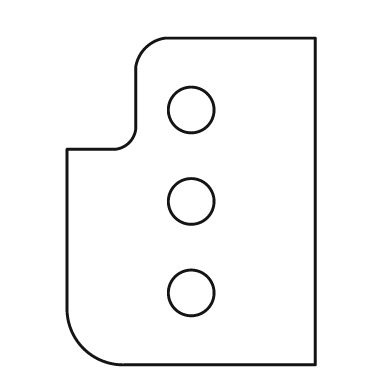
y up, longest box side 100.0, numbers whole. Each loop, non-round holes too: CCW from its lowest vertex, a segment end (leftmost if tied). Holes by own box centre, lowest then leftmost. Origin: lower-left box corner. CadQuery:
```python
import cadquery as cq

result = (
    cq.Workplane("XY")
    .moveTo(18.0, 0.0)
    .lineTo(76.0, 0.0)
    .lineTo(76.0, 100.0)
    .lineTo(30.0, 100.0)
    .threePointArc((24.0, 97.0), (21.0, 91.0))
    .lineTo(21.0, 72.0)
    .threePointArc((19.0, 68.0), (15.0, 66.0))
    .lineTo(0.0, 66.0)
    .lineTo(0.0, 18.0)
    .threePointArc((5.0, 5.0), (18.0, 0.0))
    .close()
    .moveTo(38.0, 22.0)
    .circle(7.0)
    .moveTo(38.0, 50.0)
    .circle(7.0)
    .moveTo(38.0, 78.0)
    .circle(7.0)
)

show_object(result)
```